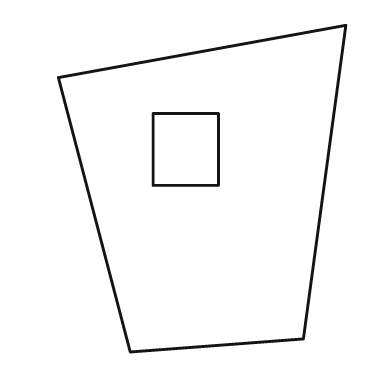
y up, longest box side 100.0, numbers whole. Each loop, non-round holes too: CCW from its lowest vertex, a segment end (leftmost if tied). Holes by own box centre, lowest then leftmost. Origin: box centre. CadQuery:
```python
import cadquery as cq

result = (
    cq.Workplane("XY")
    .moveTo(-22.0, -50.0)
    .lineTo(31.0, -46.0)
    .lineTo(44.0, 50.0)
    .lineTo(-44.0, 34.0)
    .close()
    .moveTo(-15.0, 1.0)
    .lineTo(5.0, 1.0)
    .lineTo(5.0, 23.0)
    .lineTo(-15.0, 23.0)
    .close()
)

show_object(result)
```